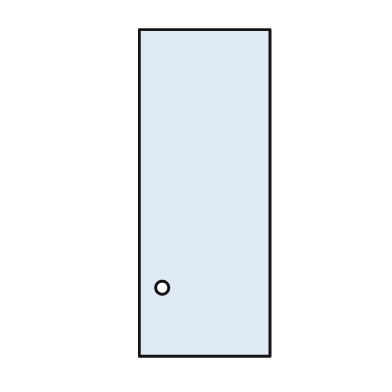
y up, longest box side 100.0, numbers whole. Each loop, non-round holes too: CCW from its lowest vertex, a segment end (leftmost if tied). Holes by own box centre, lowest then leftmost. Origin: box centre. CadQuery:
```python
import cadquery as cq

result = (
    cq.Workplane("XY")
    .moveTo(-20.0, -50.0)
    .lineTo(20.0, -50.0)
    .lineTo(20.0, 50.0)
    .lineTo(-20.0, 50.0)
    .close()
    .moveTo(-13.0, -29.0)
    .circle(2.0)
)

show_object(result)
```